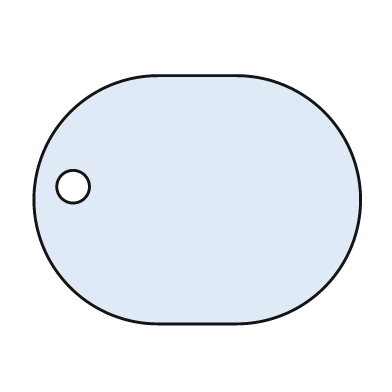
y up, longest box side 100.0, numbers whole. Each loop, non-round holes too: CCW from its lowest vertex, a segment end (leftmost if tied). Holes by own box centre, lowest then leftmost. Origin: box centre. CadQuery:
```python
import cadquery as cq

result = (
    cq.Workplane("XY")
    .moveTo(-12.0, -38.0)
    .lineTo(12.0, -38.0)
    .threePointArc((50.0, 0.0), (12.0, 38.0))
    .lineTo(-12.0, 38.0)
    .threePointArc((-50.0, 0.0), (-12.0, -38.0))
    .close()
    .moveTo(-38.0, 4.0)
    .circle(5.0)
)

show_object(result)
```